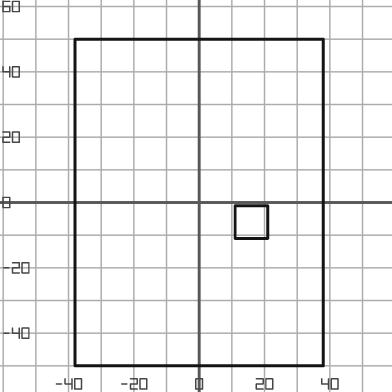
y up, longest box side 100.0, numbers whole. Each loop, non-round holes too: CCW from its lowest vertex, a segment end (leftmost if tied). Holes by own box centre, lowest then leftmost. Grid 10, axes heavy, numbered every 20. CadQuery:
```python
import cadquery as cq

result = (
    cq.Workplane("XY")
    .moveTo(-38.0, -50.0)
    .lineTo(38.0, -50.0)
    .lineTo(38.0, 50.0)
    .lineTo(-38.0, 50.0)
    .close()
    .moveTo(11.0, -11.0)
    .lineTo(21.0, -11.0)
    .lineTo(21.0, -1.0)
    .lineTo(11.0, -1.0)
    .close()
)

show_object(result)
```